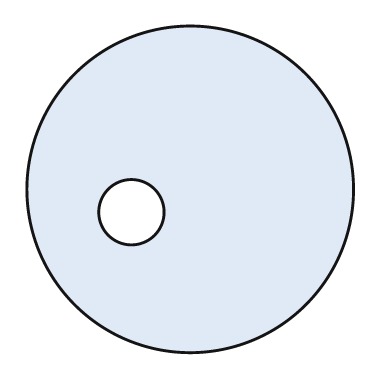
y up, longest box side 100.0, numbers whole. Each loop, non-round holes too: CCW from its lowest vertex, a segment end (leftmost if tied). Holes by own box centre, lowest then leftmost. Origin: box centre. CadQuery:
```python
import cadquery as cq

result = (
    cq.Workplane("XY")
    .moveTo(0.0, 0.0)
    .circle(50.0)
    .moveTo(-18.0, -7.0)
    .circle(10.0)
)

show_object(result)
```